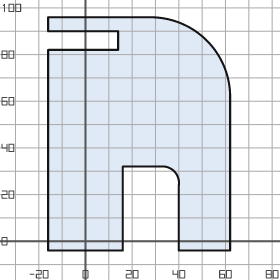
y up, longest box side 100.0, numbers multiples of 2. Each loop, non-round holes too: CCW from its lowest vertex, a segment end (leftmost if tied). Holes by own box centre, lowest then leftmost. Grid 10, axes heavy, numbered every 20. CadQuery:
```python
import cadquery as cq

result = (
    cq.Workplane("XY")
    .moveTo(-16.0, -4.0)
    .lineTo(16.0, -4.0)
    .lineTo(16.0, 32.0)
    .lineTo(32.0, 32.0)
    .threePointArc((38.0, 30.0), (40.0, 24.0))
    .lineTo(40.0, -4.0)
    .lineTo(62.0, -4.0)
    .lineTo(62.0, 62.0)
    .threePointArc((52.0, 86.0), (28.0, 96.0))
    .lineTo(-16.0, 96.0)
    .lineTo(-16.0, 90.0)
    .lineTo(14.0, 90.0)
    .lineTo(14.0, 82.0)
    .lineTo(-16.0, 82.0)
    .close()
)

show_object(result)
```